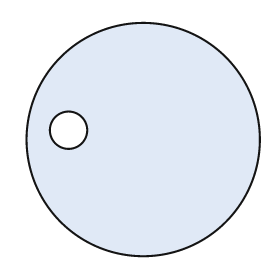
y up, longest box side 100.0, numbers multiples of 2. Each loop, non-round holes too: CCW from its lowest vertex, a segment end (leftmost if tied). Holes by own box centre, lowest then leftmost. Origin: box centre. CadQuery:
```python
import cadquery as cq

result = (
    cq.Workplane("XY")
    .moveTo(0.0, 0.0)
    .circle(50.0)
    .moveTo(-32.0, 4.0)
    .circle(8.0)
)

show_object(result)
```